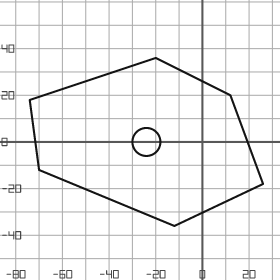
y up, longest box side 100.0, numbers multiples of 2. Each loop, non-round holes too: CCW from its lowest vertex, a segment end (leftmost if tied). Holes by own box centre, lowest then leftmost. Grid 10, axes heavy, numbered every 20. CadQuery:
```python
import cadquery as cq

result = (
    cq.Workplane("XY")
    .moveTo(-12.0, -36.0)
    .lineTo(26.0, -18.0)
    .lineTo(12.0, 20.0)
    .lineTo(-20.0, 36.0)
    .lineTo(-74.0, 18.0)
    .lineTo(-70.0, -12.0)
    .close()
    .moveTo(-24.0, 0.0)
    .circle(6.0)
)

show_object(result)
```